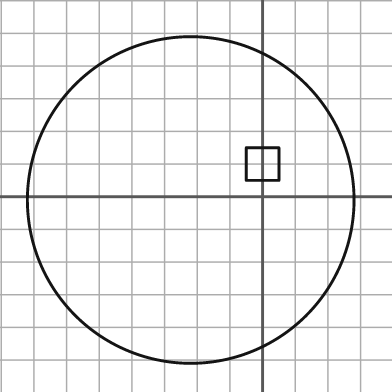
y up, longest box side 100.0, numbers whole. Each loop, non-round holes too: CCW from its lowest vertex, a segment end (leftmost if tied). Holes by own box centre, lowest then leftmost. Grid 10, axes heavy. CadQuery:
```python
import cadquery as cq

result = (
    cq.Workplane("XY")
    .moveTo(-22.0, -1.0)
    .circle(50.0)
    .moveTo(-5.0, 5.0)
    .lineTo(5.0, 5.0)
    .lineTo(5.0, 15.0)
    .lineTo(-5.0, 15.0)
    .close()
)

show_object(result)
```